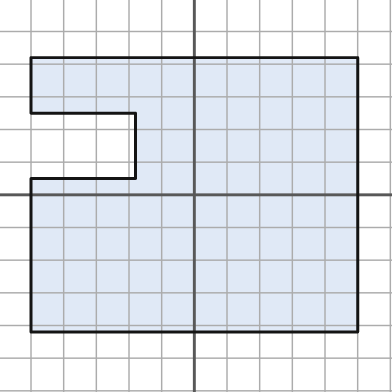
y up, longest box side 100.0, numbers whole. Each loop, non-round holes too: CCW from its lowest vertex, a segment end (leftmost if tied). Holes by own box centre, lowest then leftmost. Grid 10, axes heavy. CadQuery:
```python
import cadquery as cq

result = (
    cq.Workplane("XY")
    .moveTo(-50.0, -42.0)
    .lineTo(50.0, -42.0)
    .lineTo(50.0, 42.0)
    .lineTo(-50.0, 42.0)
    .lineTo(-50.0, 25.0)
    .lineTo(-18.0, 25.0)
    .lineTo(-18.0, 5.0)
    .lineTo(-50.0, 5.0)
    .close()
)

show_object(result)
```